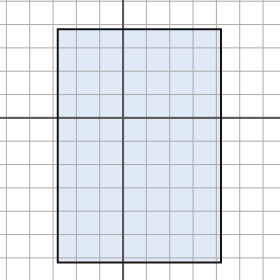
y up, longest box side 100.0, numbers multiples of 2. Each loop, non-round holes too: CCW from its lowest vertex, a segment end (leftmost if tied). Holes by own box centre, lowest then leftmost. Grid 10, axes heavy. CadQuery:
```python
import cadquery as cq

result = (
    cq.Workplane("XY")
    .moveTo(-28.0, -62.0)
    .lineTo(42.0, -62.0)
    .lineTo(42.0, 38.0)
    .lineTo(-28.0, 38.0)
    .close()
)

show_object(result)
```